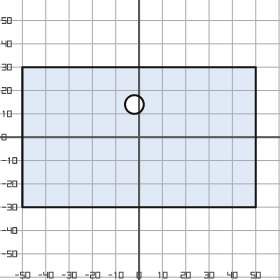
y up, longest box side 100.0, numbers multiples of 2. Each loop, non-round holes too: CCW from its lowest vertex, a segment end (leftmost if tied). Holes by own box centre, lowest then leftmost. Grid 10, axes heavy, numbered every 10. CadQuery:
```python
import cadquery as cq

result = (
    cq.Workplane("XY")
    .moveTo(-50.0, -30.0)
    .lineTo(50.0, -30.0)
    .lineTo(50.0, 30.0)
    .lineTo(-50.0, 30.0)
    .close()
    .moveTo(-2.0, 14.0)
    .circle(4.0)
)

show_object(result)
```